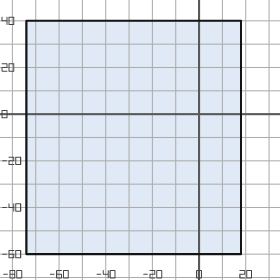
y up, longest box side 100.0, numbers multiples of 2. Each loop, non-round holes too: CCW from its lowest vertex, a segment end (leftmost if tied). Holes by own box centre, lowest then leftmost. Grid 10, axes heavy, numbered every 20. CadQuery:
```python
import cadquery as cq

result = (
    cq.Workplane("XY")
    .moveTo(-74.0, -60.0)
    .lineTo(18.0, -60.0)
    .lineTo(18.0, 40.0)
    .lineTo(-74.0, 40.0)
    .close()
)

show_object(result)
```